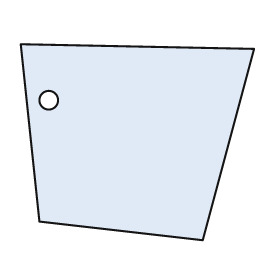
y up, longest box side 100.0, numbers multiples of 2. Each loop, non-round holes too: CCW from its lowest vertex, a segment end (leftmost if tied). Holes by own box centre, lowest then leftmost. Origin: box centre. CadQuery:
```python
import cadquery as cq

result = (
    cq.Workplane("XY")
    .moveTo(28.0, -42.0)
    .lineTo(50.0, 40.0)
    .lineTo(-50.0, 42.0)
    .lineTo(-42.0, -34.0)
    .close()
    .moveTo(-38.0, 18.0)
    .circle(4.0)
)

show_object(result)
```